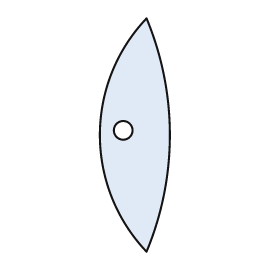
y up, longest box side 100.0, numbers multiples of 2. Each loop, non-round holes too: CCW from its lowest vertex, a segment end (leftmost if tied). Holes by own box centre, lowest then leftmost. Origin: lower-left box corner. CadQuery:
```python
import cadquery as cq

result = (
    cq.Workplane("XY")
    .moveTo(20.0, 0.0)
    .threePointArc((30.0, 50.0), (20.0, 100.0))
    .threePointArc((0.0, 50.0), (20.0, 0.0))
    .close()
    .moveTo(10.0, 52.0)
    .circle(4.0)
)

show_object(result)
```